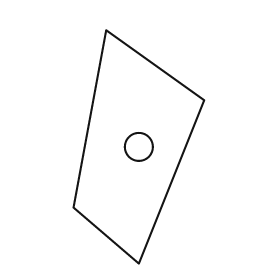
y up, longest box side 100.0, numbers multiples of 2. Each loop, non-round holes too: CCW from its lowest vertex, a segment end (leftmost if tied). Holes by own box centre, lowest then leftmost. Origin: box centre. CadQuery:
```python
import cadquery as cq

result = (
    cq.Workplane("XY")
    .moveTo(0.0, -50.0)
    .lineTo(28.0, 20.0)
    .lineTo(-14.0, 50.0)
    .lineTo(-28.0, -26.0)
    .close()
    .moveTo(0.0, 0.0)
    .circle(6.0)
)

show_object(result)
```